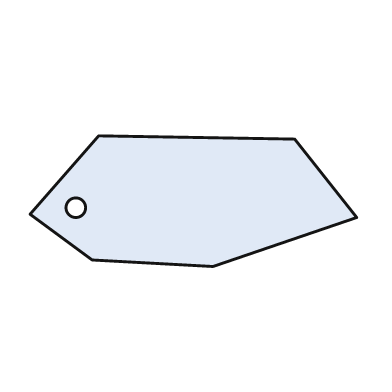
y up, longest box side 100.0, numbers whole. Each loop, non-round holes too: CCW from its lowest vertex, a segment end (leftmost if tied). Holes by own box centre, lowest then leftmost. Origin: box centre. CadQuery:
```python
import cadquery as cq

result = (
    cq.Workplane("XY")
    .moveTo(6.0, -20.0)
    .lineTo(50.0, -5.0)
    .lineTo(31.0, 19.0)
    .lineTo(-29.0, 20.0)
    .lineTo(-50.0, -4.0)
    .lineTo(-31.0, -18.0)
    .close()
    .moveTo(-36.0, -2.0)
    .circle(3.0)
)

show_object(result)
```